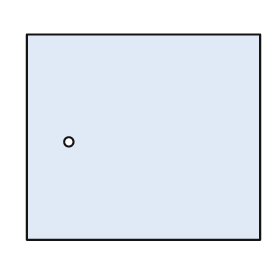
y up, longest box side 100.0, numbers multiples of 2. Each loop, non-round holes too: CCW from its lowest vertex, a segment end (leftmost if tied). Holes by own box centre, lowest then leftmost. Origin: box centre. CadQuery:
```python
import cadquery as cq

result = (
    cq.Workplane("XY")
    .moveTo(-50.0, -44.0)
    .lineTo(50.0, -44.0)
    .lineTo(50.0, 44.0)
    .lineTo(-50.0, 44.0)
    .close()
    .moveTo(-32.0, -2.0)
    .circle(2.0)
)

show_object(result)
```